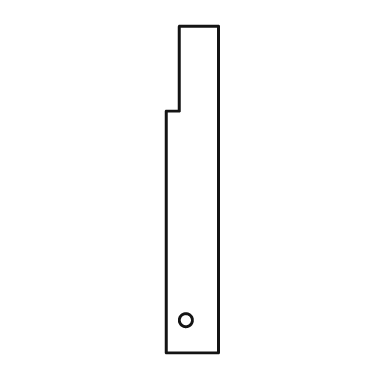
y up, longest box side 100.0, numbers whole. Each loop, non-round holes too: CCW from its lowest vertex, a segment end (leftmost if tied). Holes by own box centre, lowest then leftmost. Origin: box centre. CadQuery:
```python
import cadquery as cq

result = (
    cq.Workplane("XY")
    .moveTo(-8.0, -50.0)
    .lineTo(8.0, -50.0)
    .lineTo(8.0, 50.0)
    .lineTo(-4.0, 50.0)
    .lineTo(-4.0, 24.0)
    .lineTo(-8.0, 24.0)
    .close()
    .moveTo(-2.0, -40.0)
    .circle(2.0)
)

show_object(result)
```